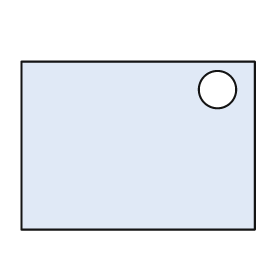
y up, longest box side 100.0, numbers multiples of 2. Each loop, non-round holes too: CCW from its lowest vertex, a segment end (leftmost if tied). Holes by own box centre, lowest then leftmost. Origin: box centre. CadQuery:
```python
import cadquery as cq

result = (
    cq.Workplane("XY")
    .moveTo(-50.0, -36.0)
    .lineTo(50.0, -36.0)
    .lineTo(50.0, 36.0)
    .lineTo(-50.0, 36.0)
    .close()
    .moveTo(34.0, 24.0)
    .circle(8.0)
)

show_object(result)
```